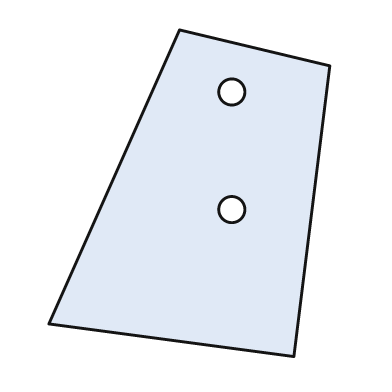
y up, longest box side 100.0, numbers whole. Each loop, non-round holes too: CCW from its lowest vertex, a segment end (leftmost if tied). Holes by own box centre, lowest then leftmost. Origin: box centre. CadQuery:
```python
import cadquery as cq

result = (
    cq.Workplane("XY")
    .moveTo(32.0, -50.0)
    .lineTo(43.0, 39.0)
    .lineTo(-3.0, 50.0)
    .lineTo(-43.0, -40.0)
    .close()
    .moveTo(13.0, -5.0)
    .circle(4.0)
    .moveTo(13.0, 31.0)
    .circle(4.0)
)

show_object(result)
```